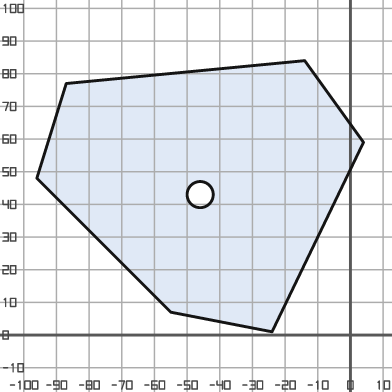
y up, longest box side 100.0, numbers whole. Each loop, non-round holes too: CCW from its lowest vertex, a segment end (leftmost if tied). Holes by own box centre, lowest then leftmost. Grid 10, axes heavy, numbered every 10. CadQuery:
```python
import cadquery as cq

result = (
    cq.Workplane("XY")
    .moveTo(-24.0, 1.0)
    .lineTo(4.0, 59.0)
    .lineTo(-14.0, 84.0)
    .lineTo(-87.0, 77.0)
    .lineTo(-96.0, 48.0)
    .lineTo(-55.0, 7.0)
    .close()
    .moveTo(-46.0, 43.0)
    .circle(4.0)
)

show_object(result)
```